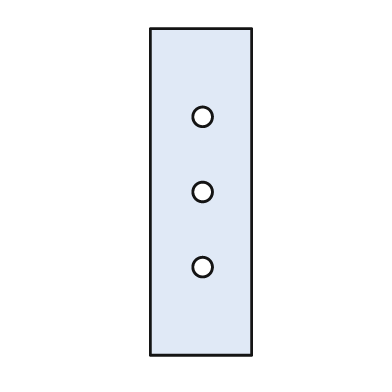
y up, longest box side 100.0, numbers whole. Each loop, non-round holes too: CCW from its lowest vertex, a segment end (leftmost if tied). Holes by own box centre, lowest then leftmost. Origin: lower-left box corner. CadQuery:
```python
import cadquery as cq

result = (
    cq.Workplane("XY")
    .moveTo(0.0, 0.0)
    .lineTo(31.0, 0.0)
    .lineTo(31.0, 100.0)
    .lineTo(0.0, 100.0)
    .close()
    .moveTo(16.0, 27.0)
    .circle(3.0)
    .moveTo(16.0, 50.0)
    .circle(3.0)
    .moveTo(16.0, 73.0)
    .circle(3.0)
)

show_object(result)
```